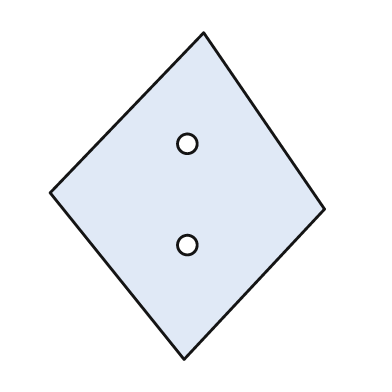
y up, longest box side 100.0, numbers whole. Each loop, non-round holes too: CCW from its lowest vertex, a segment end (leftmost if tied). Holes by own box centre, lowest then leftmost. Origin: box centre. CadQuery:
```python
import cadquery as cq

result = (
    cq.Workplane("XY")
    .moveTo(-1.0, -50.0)
    .lineTo(42.0, -4.0)
    .lineTo(5.0, 50.0)
    .lineTo(-42.0, 1.0)
    .close()
    .moveTo(0.0, -15.0)
    .circle(3.0)
    .moveTo(0.0, 16.0)
    .circle(3.0)
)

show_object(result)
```